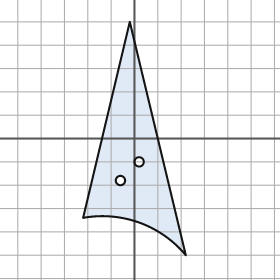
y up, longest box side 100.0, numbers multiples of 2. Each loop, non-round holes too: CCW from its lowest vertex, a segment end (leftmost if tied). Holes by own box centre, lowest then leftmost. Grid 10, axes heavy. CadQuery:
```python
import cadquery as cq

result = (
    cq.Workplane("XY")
    .moveTo(22.0, -50.0)
    .lineTo(-2.0, 50.0)
    .lineTo(-22.0, -34.0)
    .threePointArc((2.0, -36.0), (22.0, -50.0))
    .close()
    .moveTo(-6.0, -18.0)
    .circle(2.0)
    .moveTo(2.0, -10.0)
    .circle(2.0)
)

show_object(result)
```